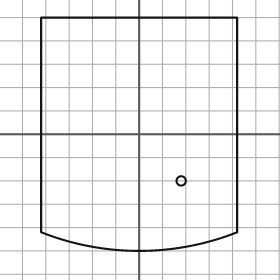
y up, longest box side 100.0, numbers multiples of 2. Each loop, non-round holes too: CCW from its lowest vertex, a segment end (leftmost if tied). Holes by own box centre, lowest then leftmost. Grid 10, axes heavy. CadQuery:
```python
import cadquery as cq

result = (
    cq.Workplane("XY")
    .moveTo(-42.0, -42.0)
    .threePointArc((0.0, -50.0), (42.0, -42.0))
    .lineTo(42.0, 50.0)
    .lineTo(-42.0, 50.0)
    .close()
    .moveTo(18.0, -20.0)
    .circle(2.0)
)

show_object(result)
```